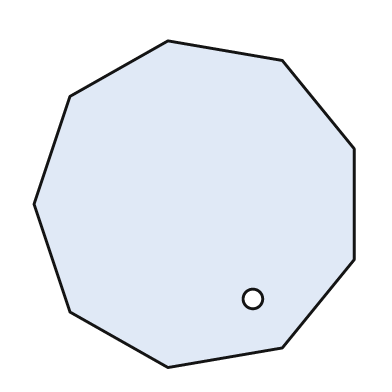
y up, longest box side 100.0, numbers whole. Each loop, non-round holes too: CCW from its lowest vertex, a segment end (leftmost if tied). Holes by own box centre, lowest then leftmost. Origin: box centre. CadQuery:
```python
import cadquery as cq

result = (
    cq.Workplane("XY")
    .moveTo(-8.0, -50.0)
    .lineTo(27.0, -44.0)
    .lineTo(49.0, -17.0)
    .lineTo(49.0, 17.0)
    .lineTo(27.0, 44.0)
    .lineTo(-8.0, 50.0)
    .lineTo(-38.0, 33.0)
    .lineTo(-49.0, 0.0)
    .lineTo(-38.0, -33.0)
    .close()
    .moveTo(18.0, -29.0)
    .circle(3.0)
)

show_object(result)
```